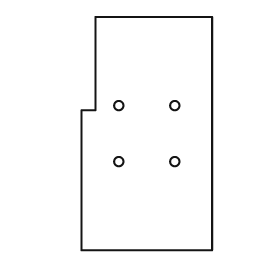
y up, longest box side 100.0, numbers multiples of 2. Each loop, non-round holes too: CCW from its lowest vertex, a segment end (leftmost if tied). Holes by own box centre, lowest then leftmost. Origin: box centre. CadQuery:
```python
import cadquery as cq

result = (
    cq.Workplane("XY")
    .moveTo(-28.0, -50.0)
    .lineTo(28.0, -50.0)
    .lineTo(28.0, 50.0)
    .lineTo(-22.0, 50.0)
    .lineTo(-22.0, 10.0)
    .lineTo(-28.0, 10.0)
    .close()
    .moveTo(-12.0, -12.0)
    .circle(2.0)
    .moveTo(12.0, -12.0)
    .circle(2.0)
    .moveTo(-12.0, 12.0)
    .circle(2.0)
    .moveTo(12.0, 12.0)
    .circle(2.0)
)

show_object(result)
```